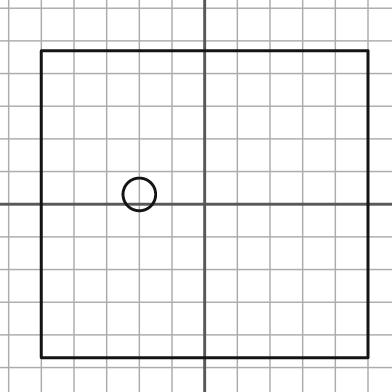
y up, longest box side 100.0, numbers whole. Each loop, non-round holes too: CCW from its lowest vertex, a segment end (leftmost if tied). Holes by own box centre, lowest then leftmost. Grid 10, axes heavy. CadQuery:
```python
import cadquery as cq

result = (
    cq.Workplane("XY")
    .moveTo(-50.0, -47.0)
    .lineTo(50.0, -47.0)
    .lineTo(50.0, 47.0)
    .lineTo(-50.0, 47.0)
    .close()
    .moveTo(-20.0, 3.0)
    .circle(5.0)
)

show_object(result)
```